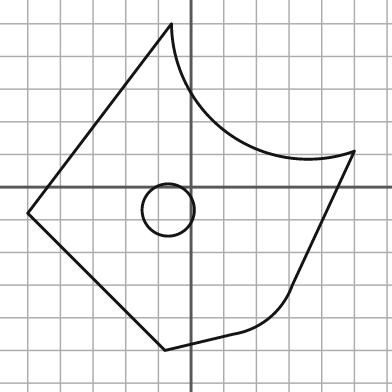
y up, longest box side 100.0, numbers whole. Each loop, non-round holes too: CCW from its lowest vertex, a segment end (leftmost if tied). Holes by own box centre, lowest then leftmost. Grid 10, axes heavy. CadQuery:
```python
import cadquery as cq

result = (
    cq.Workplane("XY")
    .moveTo(-8.0, -50.0)
    .lineTo(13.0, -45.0)
    .threePointArc((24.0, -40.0), (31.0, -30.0))
    .lineTo(50.0, 11.0)
    .threePointArc((12.0, 16.0), (-6.0, 50.0))
    .lineTo(-50.0, -8.0)
    .close()
    .moveTo(-7.0, -7.0)
    .circle(8.0)
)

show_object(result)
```